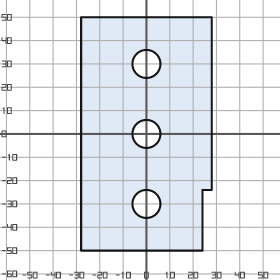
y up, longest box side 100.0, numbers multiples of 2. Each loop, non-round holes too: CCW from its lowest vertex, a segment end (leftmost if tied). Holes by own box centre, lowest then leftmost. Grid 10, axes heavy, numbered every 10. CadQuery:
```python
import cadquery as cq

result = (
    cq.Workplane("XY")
    .moveTo(-28.0, -50.0)
    .lineTo(24.0, -50.0)
    .lineTo(24.0, -24.0)
    .lineTo(28.0, -24.0)
    .lineTo(28.0, 50.0)
    .lineTo(-28.0, 50.0)
    .close()
    .moveTo(0.0, -30.0)
    .circle(6.0)
    .moveTo(0.0, 0.0)
    .circle(6.0)
    .moveTo(0.0, 30.0)
    .circle(6.0)
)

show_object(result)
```